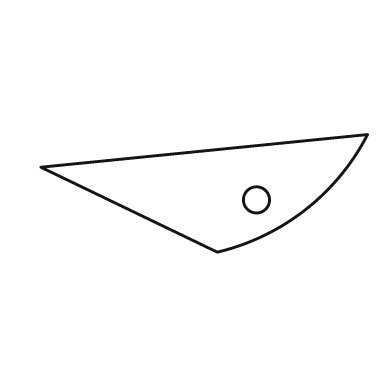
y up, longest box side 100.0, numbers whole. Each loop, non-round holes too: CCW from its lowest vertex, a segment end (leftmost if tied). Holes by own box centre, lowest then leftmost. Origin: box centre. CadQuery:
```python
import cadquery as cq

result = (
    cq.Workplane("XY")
    .moveTo(4.0, -18.0)
    .threePointArc((31.0, -5.0), (50.0, 18.0))
    .lineTo(-50.0, 8.0)
    .close()
    .moveTo(16.0, -2.0)
    .circle(4.0)
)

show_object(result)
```